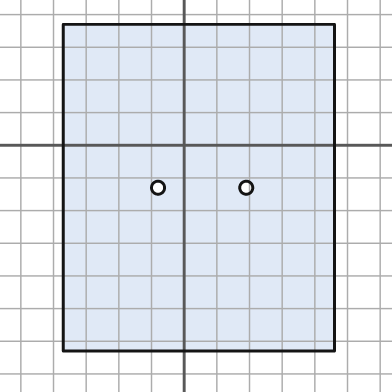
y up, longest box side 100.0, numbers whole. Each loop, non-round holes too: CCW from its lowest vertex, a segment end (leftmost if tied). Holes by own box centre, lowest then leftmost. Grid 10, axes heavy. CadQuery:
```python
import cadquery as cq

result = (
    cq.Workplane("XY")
    .moveTo(-37.0, -63.0)
    .lineTo(46.0, -63.0)
    .lineTo(46.0, 37.0)
    .lineTo(-37.0, 37.0)
    .close()
    .moveTo(-8.0, -13.0)
    .circle(2.0)
    .moveTo(19.0, -13.0)
    .circle(2.0)
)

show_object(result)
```